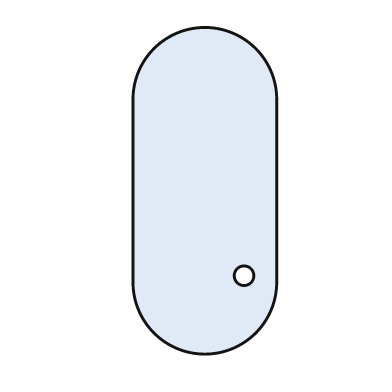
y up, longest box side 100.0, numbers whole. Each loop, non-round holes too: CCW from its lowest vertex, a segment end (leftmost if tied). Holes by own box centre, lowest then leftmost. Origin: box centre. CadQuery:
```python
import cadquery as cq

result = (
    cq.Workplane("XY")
    .moveTo(-22.0, -28.0)
    .threePointArc((0.0, -50.0), (22.0, -28.0))
    .lineTo(22.0, 28.0)
    .threePointArc((0.0, 50.0), (-22.0, 28.0))
    .close()
    .moveTo(12.0, -26.0)
    .circle(3.0)
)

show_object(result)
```